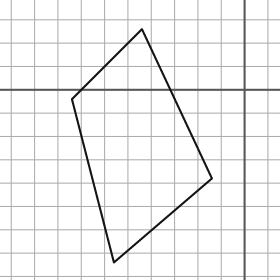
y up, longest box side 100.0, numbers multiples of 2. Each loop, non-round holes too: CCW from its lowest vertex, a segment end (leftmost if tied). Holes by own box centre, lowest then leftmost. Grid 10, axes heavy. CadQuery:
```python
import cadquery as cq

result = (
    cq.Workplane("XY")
    .moveTo(-56.0, -74.0)
    .lineTo(-14.0, -38.0)
    .lineTo(-44.0, 26.0)
    .lineTo(-74.0, -4.0)
    .close()
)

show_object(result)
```